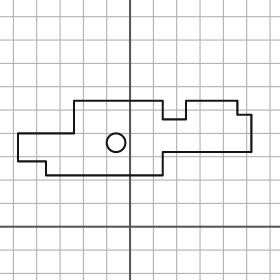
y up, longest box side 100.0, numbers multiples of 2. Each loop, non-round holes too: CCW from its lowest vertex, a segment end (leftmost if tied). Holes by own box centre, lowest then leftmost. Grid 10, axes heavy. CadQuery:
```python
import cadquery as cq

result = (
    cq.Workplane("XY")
    .moveTo(-36.0, 22.0)
    .lineTo(14.0, 22.0)
    .lineTo(14.0, 32.0)
    .lineTo(52.0, 32.0)
    .lineTo(52.0, 48.0)
    .lineTo(46.0, 48.0)
    .lineTo(46.0, 54.0)
    .lineTo(24.0, 54.0)
    .lineTo(24.0, 46.0)
    .lineTo(14.0, 46.0)
    .lineTo(14.0, 54.0)
    .lineTo(-24.0, 54.0)
    .lineTo(-24.0, 40.0)
    .lineTo(-48.0, 40.0)
    .lineTo(-48.0, 28.0)
    .lineTo(-36.0, 28.0)
    .close()
    .moveTo(-6.0, 36.0)
    .circle(4.0)
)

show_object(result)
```